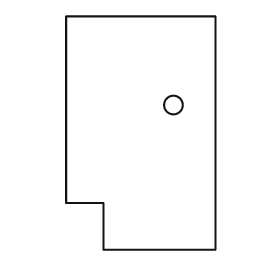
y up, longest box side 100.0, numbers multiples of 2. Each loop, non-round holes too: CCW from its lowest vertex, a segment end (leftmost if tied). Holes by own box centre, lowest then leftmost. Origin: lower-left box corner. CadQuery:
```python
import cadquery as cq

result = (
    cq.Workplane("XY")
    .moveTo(16.0, 0.0)
    .lineTo(64.0, 0.0)
    .lineTo(64.0, 100.0)
    .lineTo(0.0, 100.0)
    .lineTo(0.0, 20.0)
    .lineTo(16.0, 20.0)
    .close()
    .moveTo(46.0, 62.0)
    .circle(4.0)
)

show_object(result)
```